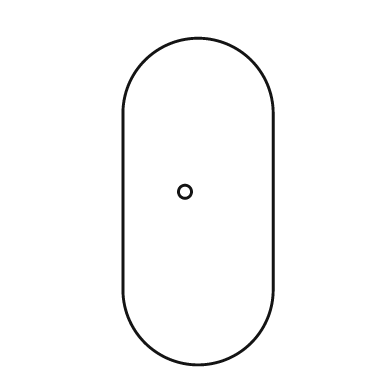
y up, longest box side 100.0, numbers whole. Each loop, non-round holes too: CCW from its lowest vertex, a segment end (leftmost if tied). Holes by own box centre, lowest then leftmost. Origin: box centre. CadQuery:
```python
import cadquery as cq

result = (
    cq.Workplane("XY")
    .moveTo(-23.0, -27.0)
    .threePointArc((0.0, -50.0), (23.0, -27.0))
    .lineTo(23.0, 27.0)
    .threePointArc((0.0, 50.0), (-23.0, 27.0))
    .close()
    .moveTo(-4.0, 3.0)
    .circle(2.0)
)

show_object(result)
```